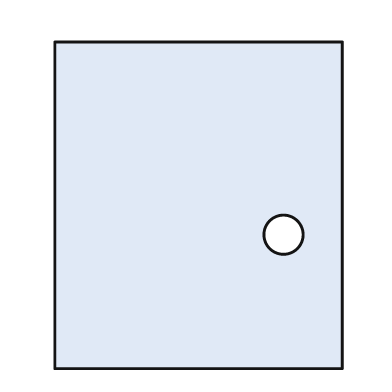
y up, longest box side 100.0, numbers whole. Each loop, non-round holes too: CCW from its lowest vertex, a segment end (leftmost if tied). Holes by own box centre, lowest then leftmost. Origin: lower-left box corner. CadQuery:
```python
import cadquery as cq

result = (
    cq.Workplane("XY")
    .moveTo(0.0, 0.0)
    .lineTo(88.0, 0.0)
    .lineTo(88.0, 100.0)
    .lineTo(0.0, 100.0)
    .close()
    .moveTo(70.0, 41.0)
    .circle(6.0)
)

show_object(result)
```